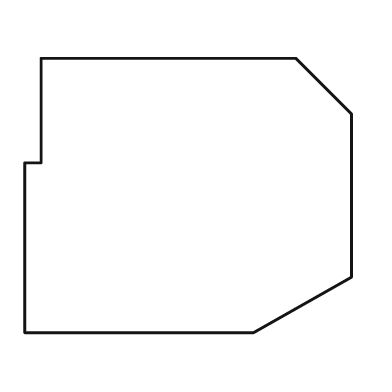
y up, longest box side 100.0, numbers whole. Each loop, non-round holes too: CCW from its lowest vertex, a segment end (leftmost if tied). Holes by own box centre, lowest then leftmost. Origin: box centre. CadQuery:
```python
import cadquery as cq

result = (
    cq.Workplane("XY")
    .moveTo(-50.0, -42.0)
    .lineTo(20.0, -42.0)
    .lineTo(50.0, -25.0)
    .lineTo(50.0, 25.0)
    .lineTo(33.0, 42.0)
    .lineTo(-45.0, 42.0)
    .lineTo(-45.0, 10.0)
    .lineTo(-50.0, 10.0)
    .close()
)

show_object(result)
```